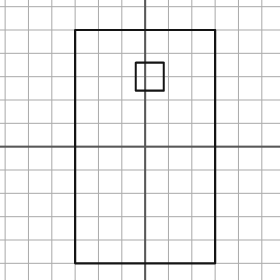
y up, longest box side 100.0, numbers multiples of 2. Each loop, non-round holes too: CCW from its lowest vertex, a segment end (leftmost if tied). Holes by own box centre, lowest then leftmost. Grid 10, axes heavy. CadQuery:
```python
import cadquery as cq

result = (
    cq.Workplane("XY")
    .moveTo(-30.0, -50.0)
    .lineTo(30.0, -50.0)
    .lineTo(30.0, 50.0)
    .lineTo(-30.0, 50.0)
    .close()
    .moveTo(-4.0, 24.0)
    .lineTo(8.0, 24.0)
    .lineTo(8.0, 36.0)
    .lineTo(-4.0, 36.0)
    .close()
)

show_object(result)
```